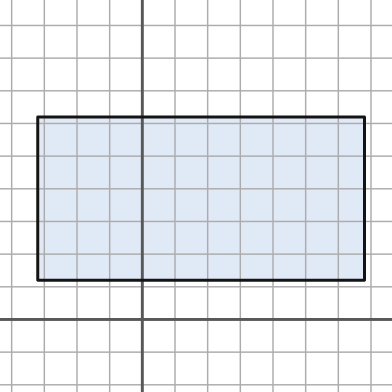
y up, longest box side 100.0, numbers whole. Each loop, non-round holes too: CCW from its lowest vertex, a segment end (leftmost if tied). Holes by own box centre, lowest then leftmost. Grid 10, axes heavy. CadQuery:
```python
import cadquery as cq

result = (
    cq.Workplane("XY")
    .moveTo(-32.0, 12.0)
    .lineTo(68.0, 12.0)
    .lineTo(68.0, 62.0)
    .lineTo(-32.0, 62.0)
    .close()
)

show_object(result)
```